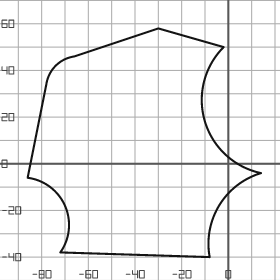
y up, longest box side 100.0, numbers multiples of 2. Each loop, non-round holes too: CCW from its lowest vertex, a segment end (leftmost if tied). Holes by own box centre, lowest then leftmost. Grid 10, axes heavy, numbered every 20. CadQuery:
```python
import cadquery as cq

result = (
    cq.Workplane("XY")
    .moveTo(-8.0, -40.0)
    .threePointArc((-4.0, -18.0), (14.0, -4.0))
    .threePointArc((-10.0, 18.0), (-2.0, 50.0))
    .lineTo(-30.0, 58.0)
    .lineTo(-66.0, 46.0)
    .threePointArc((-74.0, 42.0), (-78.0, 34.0))
    .lineTo(-86.0, -6.0)
    .threePointArc((-70.0, -18.0), (-72.0, -38.0))
    .close()
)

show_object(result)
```